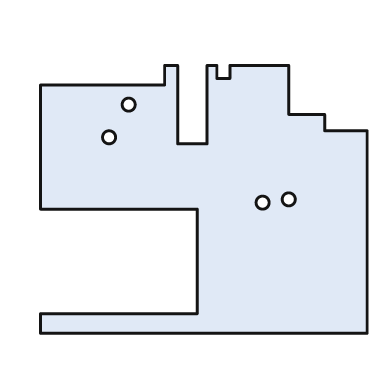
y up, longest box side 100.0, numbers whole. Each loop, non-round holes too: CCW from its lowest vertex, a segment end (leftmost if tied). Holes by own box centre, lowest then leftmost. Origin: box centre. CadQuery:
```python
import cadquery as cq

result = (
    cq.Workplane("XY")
    .moveTo(-50.0, -41.0)
    .lineTo(50.0, -41.0)
    .lineTo(50.0, 21.0)
    .lineTo(37.0, 21.0)
    .lineTo(37.0, 26.0)
    .lineTo(26.0, 26.0)
    .lineTo(26.0, 41.0)
    .lineTo(8.0, 41.0)
    .lineTo(8.0, 37.0)
    .lineTo(4.0, 37.0)
    .lineTo(4.0, 41.0)
    .lineTo(1.0, 41.0)
    .lineTo(1.0, 17.0)
    .lineTo(-8.0, 17.0)
    .lineTo(-8.0, 41.0)
    .lineTo(-12.0, 41.0)
    .lineTo(-12.0, 35.0)
    .lineTo(-50.0, 35.0)
    .lineTo(-50.0, -3.0)
    .lineTo(-2.0, -3.0)
    .lineTo(-2.0, -35.0)
    .lineTo(-50.0, -35.0)
    .close()
    .moveTo(18.0, -1.0)
    .circle(2.0)
    .moveTo(26.0, 0.0)
    .circle(2.0)
    .moveTo(-29.0, 19.0)
    .circle(2.0)
    .moveTo(-23.0, 29.0)
    .circle(2.0)
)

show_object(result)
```